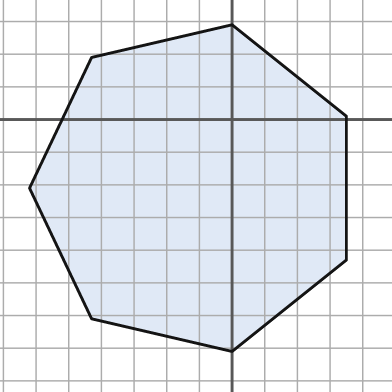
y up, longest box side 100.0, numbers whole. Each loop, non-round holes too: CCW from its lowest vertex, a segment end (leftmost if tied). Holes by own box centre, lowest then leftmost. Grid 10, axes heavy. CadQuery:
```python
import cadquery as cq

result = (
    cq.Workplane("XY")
    .moveTo(0.0, -71.0)
    .lineTo(35.0, -43.0)
    .lineTo(35.0, 1.0)
    .lineTo(0.0, 29.0)
    .lineTo(-43.0, 19.0)
    .lineTo(-62.0, -21.0)
    .lineTo(-43.0, -61.0)
    .close()
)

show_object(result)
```